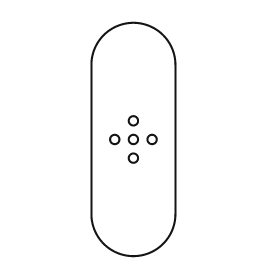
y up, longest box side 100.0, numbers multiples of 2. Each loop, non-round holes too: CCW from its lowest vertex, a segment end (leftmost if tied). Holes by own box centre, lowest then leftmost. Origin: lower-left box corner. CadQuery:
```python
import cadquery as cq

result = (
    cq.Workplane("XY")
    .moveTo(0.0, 18.0)
    .threePointArc((18.0, 0.0), (36.0, 18.0))
    .lineTo(36.0, 82.0)
    .threePointArc((18.0, 100.0), (0.0, 82.0))
    .close()
    .moveTo(18.0, 42.0)
    .circle(2.0)
    .moveTo(10.0, 50.0)
    .circle(2.0)
    .moveTo(18.0, 50.0)
    .circle(2.0)
    .moveTo(26.0, 50.0)
    .circle(2.0)
    .moveTo(18.0, 58.0)
    .circle(2.0)
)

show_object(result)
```